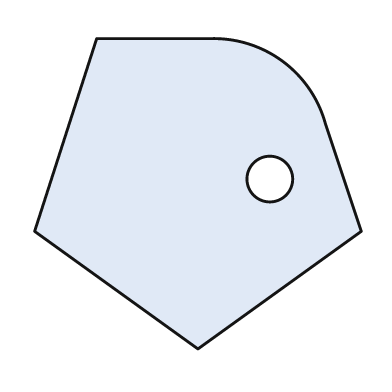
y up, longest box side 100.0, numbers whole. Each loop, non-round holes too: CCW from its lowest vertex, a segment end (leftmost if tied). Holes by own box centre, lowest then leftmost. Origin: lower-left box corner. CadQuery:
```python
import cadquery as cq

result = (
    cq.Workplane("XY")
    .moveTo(50.0, 0.0)
    .lineTo(100.0, 36.0)
    .lineTo(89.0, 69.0)
    .threePointArc((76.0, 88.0), (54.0, 95.0))
    .lineTo(19.0, 95.0)
    .lineTo(0.0, 36.0)
    .close()
    .moveTo(72.0, 52.0)
    .circle(7.0)
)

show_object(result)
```